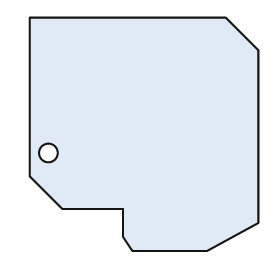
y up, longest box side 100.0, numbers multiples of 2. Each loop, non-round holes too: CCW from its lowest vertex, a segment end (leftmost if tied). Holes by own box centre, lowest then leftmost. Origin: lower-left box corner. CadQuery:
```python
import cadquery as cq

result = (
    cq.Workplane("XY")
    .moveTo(44.0, 0.0)
    .lineTo(76.0, 0.0)
    .lineTo(98.0, 12.0)
    .lineTo(98.0, 86.0)
    .lineTo(84.0, 100.0)
    .lineTo(0.0, 100.0)
    .lineTo(0.0, 32.0)
    .lineTo(14.0, 18.0)
    .lineTo(40.0, 18.0)
    .lineTo(40.0, 6.0)
    .close()
    .moveTo(8.0, 42.0)
    .circle(4.0)
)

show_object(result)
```